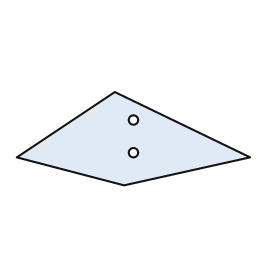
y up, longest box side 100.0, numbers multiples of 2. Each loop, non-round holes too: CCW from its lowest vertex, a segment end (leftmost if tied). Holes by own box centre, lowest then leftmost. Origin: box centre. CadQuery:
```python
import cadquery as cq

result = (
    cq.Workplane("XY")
    .moveTo(-4.0, -20.0)
    .lineTo(50.0, -8.0)
    .lineTo(-8.0, 20.0)
    .lineTo(-50.0, -8.0)
    .close()
    .moveTo(0.0, -6.0)
    .circle(2.0)
    .moveTo(0.0, 8.0)
    .circle(2.0)
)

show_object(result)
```